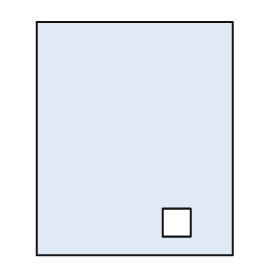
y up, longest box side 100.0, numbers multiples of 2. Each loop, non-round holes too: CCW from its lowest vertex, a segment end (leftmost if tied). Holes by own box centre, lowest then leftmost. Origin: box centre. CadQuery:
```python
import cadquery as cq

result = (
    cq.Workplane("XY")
    .moveTo(-42.0, -50.0)
    .lineTo(42.0, -50.0)
    .lineTo(42.0, 50.0)
    .lineTo(-42.0, 50.0)
    .close()
    .moveTo(12.0, -42.0)
    .lineTo(24.0, -42.0)
    .lineTo(24.0, -30.0)
    .lineTo(12.0, -30.0)
    .close()
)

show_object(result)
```